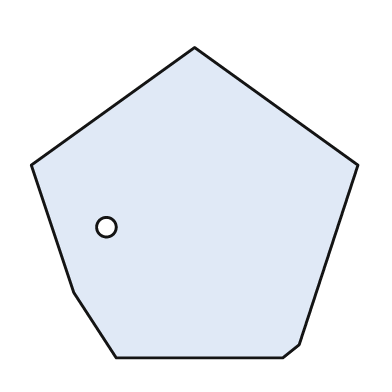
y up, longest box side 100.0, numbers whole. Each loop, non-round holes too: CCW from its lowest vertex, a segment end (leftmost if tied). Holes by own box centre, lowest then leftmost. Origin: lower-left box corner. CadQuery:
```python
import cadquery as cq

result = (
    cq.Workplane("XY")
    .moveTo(26.0, 0.0)
    .lineTo(77.0, 0.0)
    .lineTo(82.0, 4.0)
    .lineTo(100.0, 59.0)
    .lineTo(50.0, 95.0)
    .lineTo(0.0, 59.0)
    .lineTo(13.0, 20.0)
    .close()
    .moveTo(23.0, 40.0)
    .circle(3.0)
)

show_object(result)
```